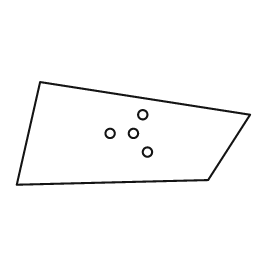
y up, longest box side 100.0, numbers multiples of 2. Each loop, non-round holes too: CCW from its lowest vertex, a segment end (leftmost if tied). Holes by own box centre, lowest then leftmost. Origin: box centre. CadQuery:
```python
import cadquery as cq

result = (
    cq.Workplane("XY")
    .moveTo(-50.0, -22.0)
    .lineTo(32.0, -20.0)
    .lineTo(50.0, 8.0)
    .lineTo(-40.0, 22.0)
    .close()
    .moveTo(6.0, -8.0)
    .circle(2.0)
    .moveTo(-10.0, 0.0)
    .circle(2.0)
    .moveTo(0.0, 0.0)
    .circle(2.0)
    .moveTo(4.0, 8.0)
    .circle(2.0)
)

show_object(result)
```